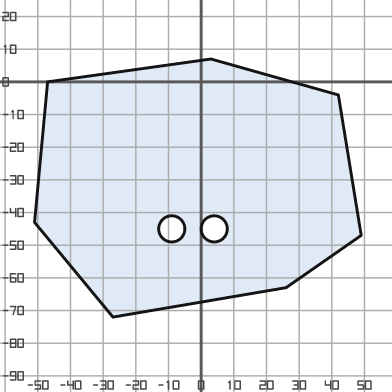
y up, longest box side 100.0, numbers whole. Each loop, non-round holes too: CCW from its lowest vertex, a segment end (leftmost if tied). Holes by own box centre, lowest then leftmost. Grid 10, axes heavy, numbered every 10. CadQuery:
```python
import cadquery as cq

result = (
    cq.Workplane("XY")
    .moveTo(-27.0, -72.0)
    .lineTo(26.0, -63.0)
    .lineTo(49.0, -47.0)
    .lineTo(42.0, -4.0)
    .lineTo(3.0, 7.0)
    .lineTo(-47.0, 0.0)
    .lineTo(-51.0, -43.0)
    .close()
    .moveTo(-9.0, -45.0)
    .circle(4.0)
    .moveTo(4.0, -45.0)
    .circle(4.0)
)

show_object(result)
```